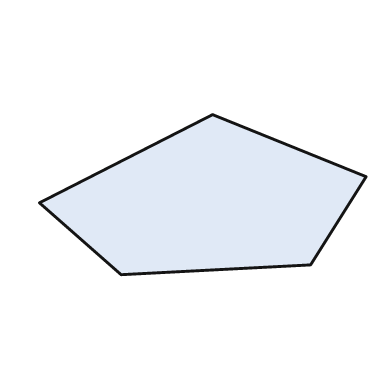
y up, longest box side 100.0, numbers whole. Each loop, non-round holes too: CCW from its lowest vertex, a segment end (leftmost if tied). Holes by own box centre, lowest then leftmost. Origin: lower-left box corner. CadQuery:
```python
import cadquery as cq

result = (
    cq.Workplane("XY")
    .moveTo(25.0, 0.0)
    .lineTo(83.0, 3.0)
    .lineTo(100.0, 30.0)
    .lineTo(53.0, 49.0)
    .lineTo(0.0, 22.0)
    .close()
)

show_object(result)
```